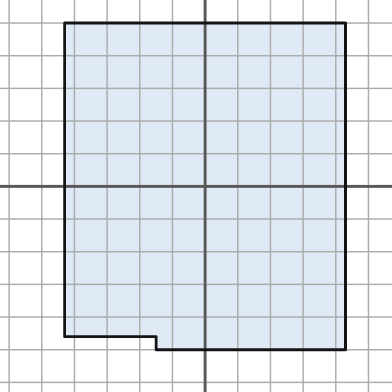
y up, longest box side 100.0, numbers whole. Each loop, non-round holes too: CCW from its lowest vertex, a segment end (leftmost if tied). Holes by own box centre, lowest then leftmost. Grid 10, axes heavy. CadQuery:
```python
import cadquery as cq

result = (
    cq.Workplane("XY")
    .moveTo(-15.0, -50.0)
    .lineTo(43.0, -50.0)
    .lineTo(43.0, 50.0)
    .lineTo(-43.0, 50.0)
    .lineTo(-43.0, -46.0)
    .lineTo(-15.0, -46.0)
    .close()
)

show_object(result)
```